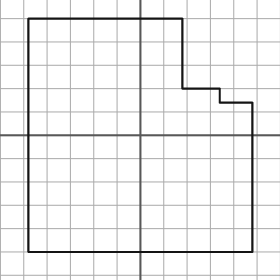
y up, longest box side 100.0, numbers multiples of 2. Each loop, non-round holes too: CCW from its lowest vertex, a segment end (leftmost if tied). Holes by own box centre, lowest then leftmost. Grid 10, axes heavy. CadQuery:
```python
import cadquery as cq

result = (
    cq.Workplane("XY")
    .moveTo(-48.0, -50.0)
    .lineTo(48.0, -50.0)
    .lineTo(48.0, 14.0)
    .lineTo(34.0, 14.0)
    .lineTo(34.0, 20.0)
    .lineTo(18.0, 20.0)
    .lineTo(18.0, 50.0)
    .lineTo(-48.0, 50.0)
    .close()
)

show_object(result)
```